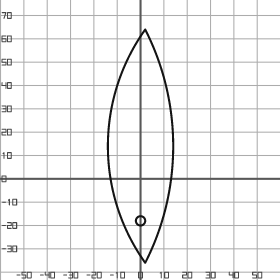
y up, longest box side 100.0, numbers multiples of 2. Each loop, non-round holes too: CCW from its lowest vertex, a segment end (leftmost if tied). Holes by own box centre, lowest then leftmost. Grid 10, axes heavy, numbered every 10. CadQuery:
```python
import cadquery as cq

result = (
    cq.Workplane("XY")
    .moveTo(2.0, -36.0)
    .threePointArc((14.0, 14.0), (2.0, 64.0))
    .threePointArc((-14.0, 14.0), (2.0, -36.0))
    .close()
    .moveTo(0.0, -18.0)
    .circle(2.0)
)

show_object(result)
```